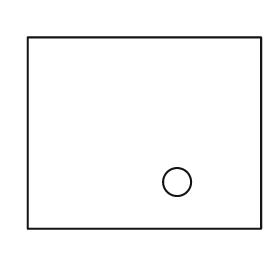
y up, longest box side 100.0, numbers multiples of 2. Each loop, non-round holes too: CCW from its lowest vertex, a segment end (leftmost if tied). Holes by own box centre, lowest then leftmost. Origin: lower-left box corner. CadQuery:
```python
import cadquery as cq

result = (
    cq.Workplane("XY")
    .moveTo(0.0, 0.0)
    .lineTo(100.0, 0.0)
    .lineTo(100.0, 82.0)
    .lineTo(0.0, 82.0)
    .close()
    .moveTo(64.0, 20.0)
    .circle(6.0)
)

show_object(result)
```